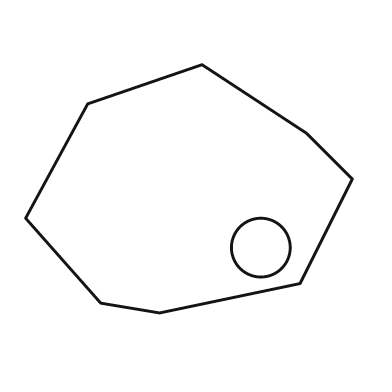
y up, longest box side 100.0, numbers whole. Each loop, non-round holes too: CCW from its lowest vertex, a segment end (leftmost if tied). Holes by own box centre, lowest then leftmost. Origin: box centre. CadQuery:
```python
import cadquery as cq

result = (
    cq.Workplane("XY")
    .moveTo(-9.0, -38.0)
    .lineTo(34.0, -29.0)
    .lineTo(50.0, 3.0)
    .lineTo(36.0, 17.0)
    .lineTo(4.0, 38.0)
    .lineTo(-31.0, 26.0)
    .lineTo(-50.0, -9.0)
    .lineTo(-27.0, -35.0)
    .close()
    .moveTo(22.0, -18.0)
    .circle(9.0)
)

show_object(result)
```